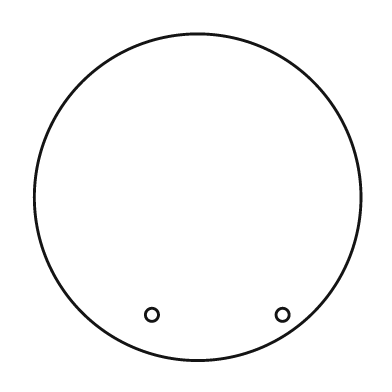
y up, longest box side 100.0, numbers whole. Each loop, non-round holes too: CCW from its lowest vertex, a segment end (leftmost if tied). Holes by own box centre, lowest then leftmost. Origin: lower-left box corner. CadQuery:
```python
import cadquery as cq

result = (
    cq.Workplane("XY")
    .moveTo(50.0, 50.0)
    .circle(50.0)
    .moveTo(36.0, 14.0)
    .circle(2.0)
    .moveTo(76.0, 14.0)
    .circle(2.0)
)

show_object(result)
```